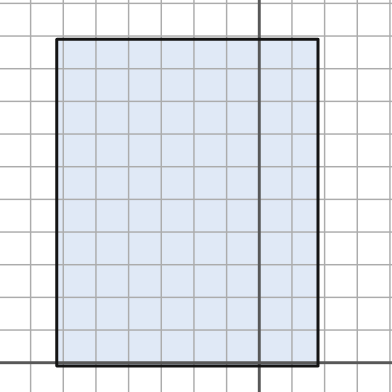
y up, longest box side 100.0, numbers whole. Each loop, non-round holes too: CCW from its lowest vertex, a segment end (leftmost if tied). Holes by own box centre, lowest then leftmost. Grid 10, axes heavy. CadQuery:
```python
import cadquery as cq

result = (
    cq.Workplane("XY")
    .moveTo(-62.0, -1.0)
    .lineTo(18.0, -1.0)
    .lineTo(18.0, 99.0)
    .lineTo(-62.0, 99.0)
    .close()
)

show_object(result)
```